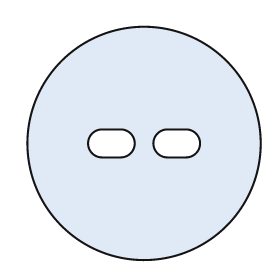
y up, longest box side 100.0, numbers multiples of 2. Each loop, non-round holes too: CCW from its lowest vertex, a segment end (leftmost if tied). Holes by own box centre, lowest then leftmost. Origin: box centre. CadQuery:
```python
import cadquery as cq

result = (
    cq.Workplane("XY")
    .moveTo(0.0, 0.0)
    .circle(50.0)
    .moveTo(-18.0, -6.0)
    .lineTo(-10.0, -6.0)
    .threePointArc((-4.0, 0.0), (-10.0, 6.0))
    .lineTo(-18.0, 6.0)
    .threePointArc((-24.0, 0.0), (-18.0, -6.0))
    .close()
    .moveTo(10.0, -6.0)
    .lineTo(18.0, -6.0)
    .threePointArc((24.0, 0.0), (18.0, 6.0))
    .lineTo(10.0, 6.0)
    .threePointArc((4.0, 0.0), (10.0, -6.0))
    .close()
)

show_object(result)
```